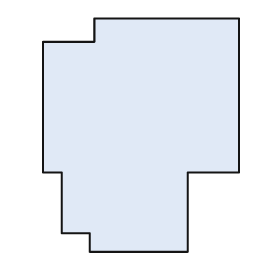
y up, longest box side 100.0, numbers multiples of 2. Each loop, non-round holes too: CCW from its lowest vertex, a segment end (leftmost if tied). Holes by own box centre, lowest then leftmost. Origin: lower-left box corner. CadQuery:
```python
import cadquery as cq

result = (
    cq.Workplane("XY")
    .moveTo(20.0, 0.0)
    .lineTo(62.0, 0.0)
    .lineTo(62.0, 34.0)
    .lineTo(84.0, 34.0)
    .lineTo(84.0, 100.0)
    .lineTo(22.0, 100.0)
    .lineTo(22.0, 90.0)
    .lineTo(0.0, 90.0)
    .lineTo(0.0, 34.0)
    .lineTo(8.0, 34.0)
    .lineTo(8.0, 8.0)
    .lineTo(20.0, 8.0)
    .close()
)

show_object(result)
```